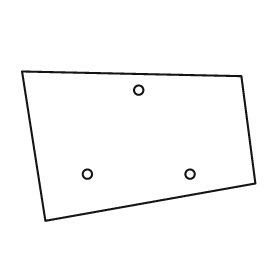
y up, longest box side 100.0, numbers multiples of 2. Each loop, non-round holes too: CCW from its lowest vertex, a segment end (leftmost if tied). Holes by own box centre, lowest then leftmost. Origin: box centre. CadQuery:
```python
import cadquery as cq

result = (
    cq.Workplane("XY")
    .moveTo(-40.0, -32.0)
    .lineTo(50.0, -16.0)
    .lineTo(44.0, 30.0)
    .lineTo(-50.0, 32.0)
    .close()
    .moveTo(-22.0, -12.0)
    .circle(2.0)
    .moveTo(22.0, -12.0)
    .circle(2.0)
    .moveTo(0.0, 24.0)
    .circle(2.0)
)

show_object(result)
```